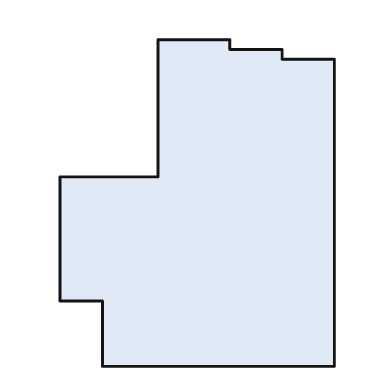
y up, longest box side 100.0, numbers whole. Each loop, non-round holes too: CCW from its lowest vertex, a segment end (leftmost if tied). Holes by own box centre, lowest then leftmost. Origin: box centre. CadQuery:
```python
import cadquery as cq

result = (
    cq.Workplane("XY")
    .moveTo(-29.0, -50.0)
    .lineTo(42.0, -50.0)
    .lineTo(42.0, 44.0)
    .lineTo(26.0, 44.0)
    .lineTo(26.0, 47.0)
    .lineTo(10.0, 47.0)
    .lineTo(10.0, 50.0)
    .lineTo(-12.0, 50.0)
    .lineTo(-12.0, 8.0)
    .lineTo(-42.0, 8.0)
    .lineTo(-42.0, -30.0)
    .lineTo(-29.0, -30.0)
    .close()
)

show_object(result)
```